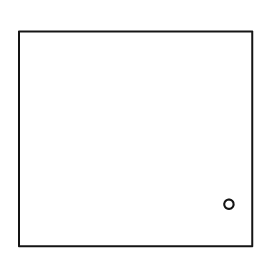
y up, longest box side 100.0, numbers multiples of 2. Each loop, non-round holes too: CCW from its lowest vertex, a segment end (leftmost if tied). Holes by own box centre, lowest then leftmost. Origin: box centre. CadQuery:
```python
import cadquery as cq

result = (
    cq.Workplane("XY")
    .moveTo(-50.0, -46.0)
    .lineTo(50.0, -46.0)
    .lineTo(50.0, 46.0)
    .lineTo(-50.0, 46.0)
    .close()
    .moveTo(40.0, -28.0)
    .circle(2.0)
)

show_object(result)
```